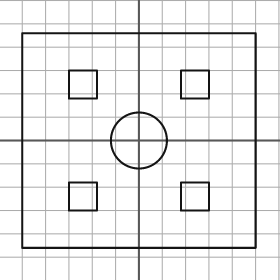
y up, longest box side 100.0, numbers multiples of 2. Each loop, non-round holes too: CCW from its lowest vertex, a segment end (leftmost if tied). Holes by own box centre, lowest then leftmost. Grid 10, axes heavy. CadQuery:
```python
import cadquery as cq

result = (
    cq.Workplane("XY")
    .moveTo(-50.0, -46.0)
    .lineTo(50.0, -46.0)
    .lineTo(50.0, 46.0)
    .lineTo(-50.0, 46.0)
    .close()
    .moveTo(-30.0, -30.0)
    .lineTo(-18.0, -30.0)
    .lineTo(-18.0, -18.0)
    .lineTo(-30.0, -18.0)
    .close()
    .moveTo(18.0, -30.0)
    .lineTo(30.0, -30.0)
    .lineTo(30.0, -18.0)
    .lineTo(18.0, -18.0)
    .close()
    .moveTo(0.0, 0.0)
    .circle(12.0)
    .moveTo(-30.0, 18.0)
    .lineTo(-18.0, 18.0)
    .lineTo(-18.0, 30.0)
    .lineTo(-30.0, 30.0)
    .close()
    .moveTo(18.0, 18.0)
    .lineTo(30.0, 18.0)
    .lineTo(30.0, 30.0)
    .lineTo(18.0, 30.0)
    .close()
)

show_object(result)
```